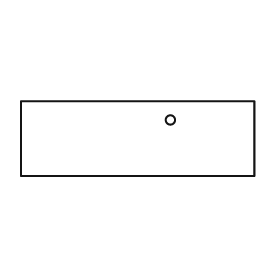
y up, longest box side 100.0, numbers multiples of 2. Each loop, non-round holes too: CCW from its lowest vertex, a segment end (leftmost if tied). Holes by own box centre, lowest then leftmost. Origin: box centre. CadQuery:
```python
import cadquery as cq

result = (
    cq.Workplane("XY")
    .moveTo(-50.0, -16.0)
    .lineTo(50.0, -16.0)
    .lineTo(50.0, 16.0)
    .lineTo(-50.0, 16.0)
    .close()
    .moveTo(14.0, 8.0)
    .circle(2.0)
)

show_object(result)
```